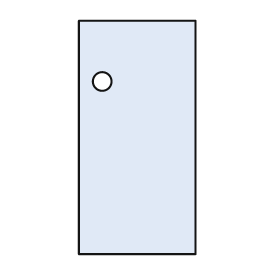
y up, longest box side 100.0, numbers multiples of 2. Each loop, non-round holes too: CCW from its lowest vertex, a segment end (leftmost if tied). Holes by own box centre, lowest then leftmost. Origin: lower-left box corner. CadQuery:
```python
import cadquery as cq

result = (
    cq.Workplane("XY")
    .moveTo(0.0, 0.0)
    .lineTo(50.0, 0.0)
    .lineTo(50.0, 100.0)
    .lineTo(0.0, 100.0)
    .close()
    .moveTo(10.0, 74.0)
    .circle(4.0)
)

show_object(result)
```